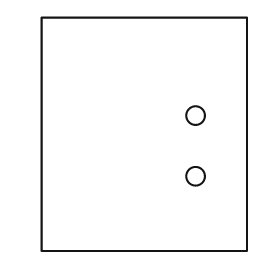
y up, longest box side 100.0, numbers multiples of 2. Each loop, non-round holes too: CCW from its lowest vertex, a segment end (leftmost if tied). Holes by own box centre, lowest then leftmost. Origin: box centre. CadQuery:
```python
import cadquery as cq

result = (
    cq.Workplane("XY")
    .moveTo(-44.0, -50.0)
    .lineTo(44.0, -50.0)
    .lineTo(44.0, 50.0)
    .lineTo(-44.0, 50.0)
    .close()
    .moveTo(22.0, -18.0)
    .circle(4.0)
    .moveTo(22.0, 8.0)
    .circle(4.0)
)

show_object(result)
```